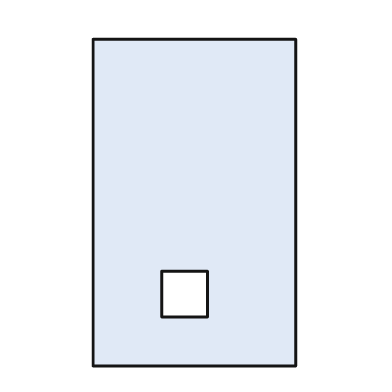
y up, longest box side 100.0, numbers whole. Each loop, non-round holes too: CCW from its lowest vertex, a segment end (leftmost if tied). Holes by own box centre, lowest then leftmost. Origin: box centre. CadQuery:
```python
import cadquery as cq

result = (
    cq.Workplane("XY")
    .moveTo(-31.0, -50.0)
    .lineTo(31.0, -50.0)
    .lineTo(31.0, 50.0)
    .lineTo(-31.0, 50.0)
    .close()
    .moveTo(-10.0, -35.0)
    .lineTo(4.0, -35.0)
    .lineTo(4.0, -21.0)
    .lineTo(-10.0, -21.0)
    .close()
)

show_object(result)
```